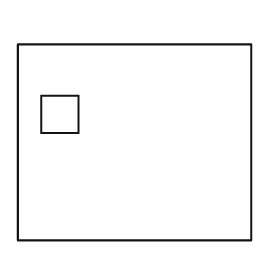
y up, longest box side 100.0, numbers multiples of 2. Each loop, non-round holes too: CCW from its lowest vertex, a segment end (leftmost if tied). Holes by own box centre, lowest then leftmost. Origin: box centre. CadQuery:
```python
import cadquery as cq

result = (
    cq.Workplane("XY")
    .moveTo(-50.0, -42.0)
    .lineTo(50.0, -42.0)
    .lineTo(50.0, 42.0)
    .lineTo(-50.0, 42.0)
    .close()
    .moveTo(-40.0, 4.0)
    .lineTo(-24.0, 4.0)
    .lineTo(-24.0, 20.0)
    .lineTo(-40.0, 20.0)
    .close()
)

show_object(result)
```